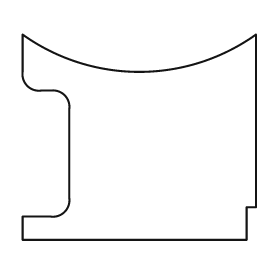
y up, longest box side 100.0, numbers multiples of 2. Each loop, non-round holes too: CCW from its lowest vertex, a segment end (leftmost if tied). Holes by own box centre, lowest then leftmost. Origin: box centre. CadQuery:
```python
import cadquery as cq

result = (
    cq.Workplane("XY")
    .moveTo(-50.0, -44.0)
    .lineTo(46.0, -44.0)
    .lineTo(46.0, -30.0)
    .lineTo(50.0, -30.0)
    .lineTo(50.0, 44.0)
    .threePointArc((0.0, 28.0), (-50.0, 44.0))
    .lineTo(-50.0, 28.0)
    .threePointArc((-48.0, 22.0), (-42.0, 20.0))
    .lineTo(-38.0, 20.0)
    .threePointArc((-32.0, 18.0), (-30.0, 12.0))
    .lineTo(-30.0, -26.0)
    .threePointArc((-32.0, -32.0), (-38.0, -34.0))
    .lineTo(-50.0, -34.0)
    .close()
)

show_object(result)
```